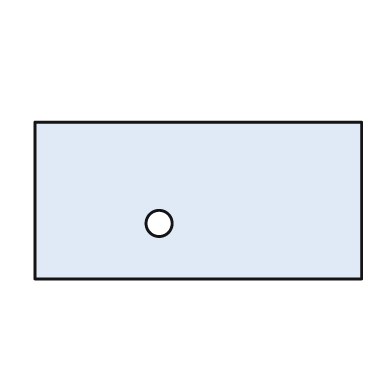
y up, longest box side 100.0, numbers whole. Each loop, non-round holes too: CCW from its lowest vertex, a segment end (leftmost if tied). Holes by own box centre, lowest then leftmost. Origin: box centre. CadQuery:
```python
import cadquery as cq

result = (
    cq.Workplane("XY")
    .moveTo(-50.0, -24.0)
    .lineTo(50.0, -24.0)
    .lineTo(50.0, 24.0)
    .lineTo(-50.0, 24.0)
    .close()
    .moveTo(-12.0, -7.0)
    .circle(4.0)
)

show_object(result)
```